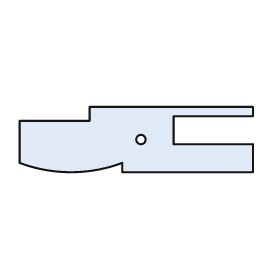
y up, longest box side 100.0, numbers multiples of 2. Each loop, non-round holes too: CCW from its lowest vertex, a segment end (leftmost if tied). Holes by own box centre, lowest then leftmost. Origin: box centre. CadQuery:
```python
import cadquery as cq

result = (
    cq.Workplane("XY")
    .moveTo(-6.0, -14.0)
    .lineTo(50.0, -14.0)
    .lineTo(50.0, -2.0)
    .lineTo(16.0, -2.0)
    .lineTo(16.0, 10.0)
    .lineTo(50.0, 10.0)
    .lineTo(50.0, 14.0)
    .lineTo(-20.0, 14.0)
    .lineTo(-20.0, 8.0)
    .lineTo(-50.0, 8.0)
    .lineTo(-50.0, -10.0)
    .threePointArc((-28.0, -14.0), (-6.0, -10.0))
    .close()
    .moveTo(2.0, 0.0)
    .circle(2.0)
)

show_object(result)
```